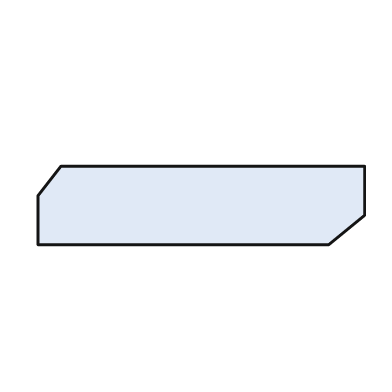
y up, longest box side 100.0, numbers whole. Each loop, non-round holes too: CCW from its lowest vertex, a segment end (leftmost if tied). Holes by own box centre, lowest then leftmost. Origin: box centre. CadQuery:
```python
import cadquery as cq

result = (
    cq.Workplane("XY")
    .moveTo(-50.0, -12.0)
    .lineTo(39.0, -12.0)
    .lineTo(50.0, -3.0)
    .lineTo(50.0, 12.0)
    .lineTo(-43.0, 12.0)
    .lineTo(-50.0, 3.0)
    .close()
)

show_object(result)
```